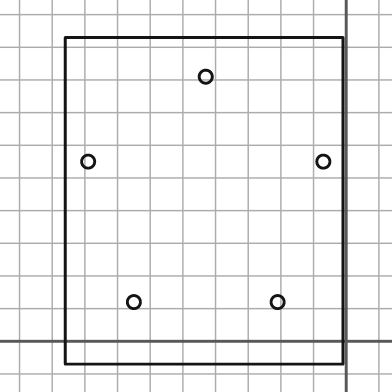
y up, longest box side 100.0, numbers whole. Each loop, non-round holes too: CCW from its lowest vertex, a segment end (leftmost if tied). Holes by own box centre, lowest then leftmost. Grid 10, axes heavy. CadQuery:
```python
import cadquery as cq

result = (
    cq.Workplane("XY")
    .moveTo(-86.0, -7.0)
    .lineTo(-1.0, -7.0)
    .lineTo(-1.0, 93.0)
    .lineTo(-86.0, 93.0)
    .close()
    .moveTo(-65.0, 12.0)
    .circle(2.0)
    .moveTo(-21.0, 12.0)
    .circle(2.0)
    .moveTo(-79.0, 55.0)
    .circle(2.0)
    .moveTo(-7.0, 55.0)
    .circle(2.0)
    .moveTo(-43.0, 81.0)
    .circle(2.0)
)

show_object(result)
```